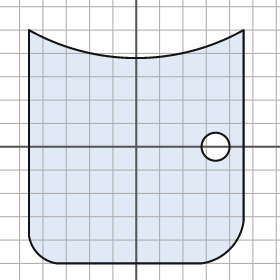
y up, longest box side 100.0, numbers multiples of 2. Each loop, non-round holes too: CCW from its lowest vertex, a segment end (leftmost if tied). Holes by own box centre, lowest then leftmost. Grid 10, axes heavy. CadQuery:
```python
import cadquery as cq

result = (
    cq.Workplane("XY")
    .moveTo(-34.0, -50.0)
    .lineTo(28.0, -50.0)
    .threePointArc((40.0, -44.0), (46.0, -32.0))
    .lineTo(46.0, 50.0)
    .threePointArc((0.0, 38.0), (-46.0, 50.0))
    .lineTo(-46.0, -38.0)
    .threePointArc((-42.0, -46.0), (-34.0, -50.0))
    .close()
    .moveTo(34.0, 0.0)
    .circle(6.0)
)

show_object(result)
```